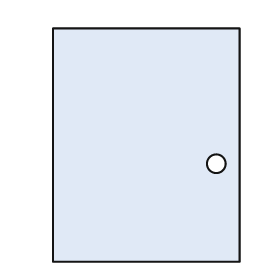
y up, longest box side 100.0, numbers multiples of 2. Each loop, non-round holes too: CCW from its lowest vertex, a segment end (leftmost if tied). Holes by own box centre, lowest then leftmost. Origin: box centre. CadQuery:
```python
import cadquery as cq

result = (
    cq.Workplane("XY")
    .moveTo(-40.0, -50.0)
    .lineTo(40.0, -50.0)
    .lineTo(40.0, 50.0)
    .lineTo(-40.0, 50.0)
    .close()
    .moveTo(30.0, -8.0)
    .circle(4.0)
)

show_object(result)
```